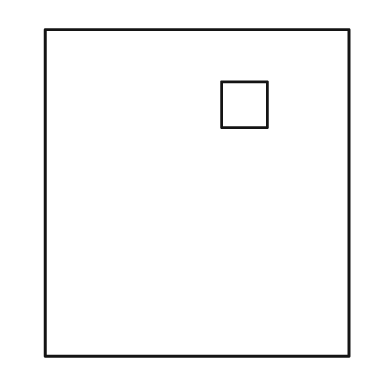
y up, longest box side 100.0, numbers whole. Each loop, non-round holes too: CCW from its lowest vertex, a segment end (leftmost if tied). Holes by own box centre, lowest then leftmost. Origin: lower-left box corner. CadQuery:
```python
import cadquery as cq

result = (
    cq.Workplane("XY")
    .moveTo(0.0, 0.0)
    .lineTo(93.0, 0.0)
    .lineTo(93.0, 100.0)
    .lineTo(0.0, 100.0)
    .close()
    .moveTo(54.0, 70.0)
    .lineTo(68.0, 70.0)
    .lineTo(68.0, 84.0)
    .lineTo(54.0, 84.0)
    .close()
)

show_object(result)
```